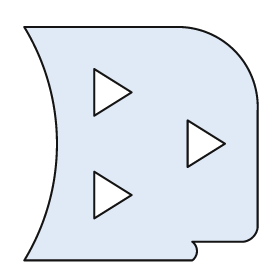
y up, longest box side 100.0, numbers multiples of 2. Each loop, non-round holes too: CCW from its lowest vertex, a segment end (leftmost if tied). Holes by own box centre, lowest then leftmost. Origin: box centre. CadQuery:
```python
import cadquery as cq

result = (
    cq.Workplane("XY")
    .moveTo(-50.0, -50.0)
    .lineTo(22.0, -50.0)
    .threePointArc((24.0, -46.0), (22.0, -42.0))
    .lineTo(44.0, -42.0)
    .threePointArc((48.0, -40.0), (50.0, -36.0))
    .lineTo(50.0, 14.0)
    .threePointArc((40.0, 40.0), (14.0, 50.0))
    .lineTo(-50.0, 50.0)
    .threePointArc((-36.0, 0.0), (-50.0, -50.0))
    .close()
    .moveTo(-20.0, -32.0)
    .lineTo(-4.0, -22.0)
    .lineTo(-20.0, -12.0)
    .close()
    .moveTo(20.0, -10.0)
    .lineTo(36.0, 0.0)
    .lineTo(20.0, 10.0)
    .close()
    .moveTo(-20.0, 12.0)
    .lineTo(-4.0, 22.0)
    .lineTo(-20.0, 32.0)
    .close()
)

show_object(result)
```